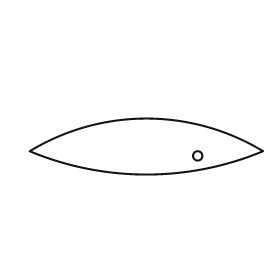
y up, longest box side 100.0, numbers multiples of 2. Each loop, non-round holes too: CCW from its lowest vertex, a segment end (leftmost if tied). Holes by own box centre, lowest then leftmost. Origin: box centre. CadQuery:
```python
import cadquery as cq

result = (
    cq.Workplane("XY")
    .moveTo(-50.0, -2.0)
    .threePointArc((0.0, -12.0), (50.0, -2.0))
    .threePointArc((0.0, 12.0), (-50.0, -2.0))
    .close()
    .moveTo(22.0, -4.0)
    .circle(2.0)
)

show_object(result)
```